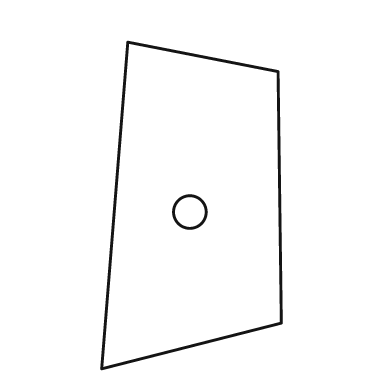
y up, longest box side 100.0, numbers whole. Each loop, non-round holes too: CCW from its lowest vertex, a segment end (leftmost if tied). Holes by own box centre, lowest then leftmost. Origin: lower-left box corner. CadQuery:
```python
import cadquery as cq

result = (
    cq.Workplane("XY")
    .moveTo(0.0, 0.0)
    .lineTo(55.0, 14.0)
    .lineTo(54.0, 91.0)
    .lineTo(8.0, 100.0)
    .close()
    .moveTo(27.0, 48.0)
    .circle(5.0)
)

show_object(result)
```